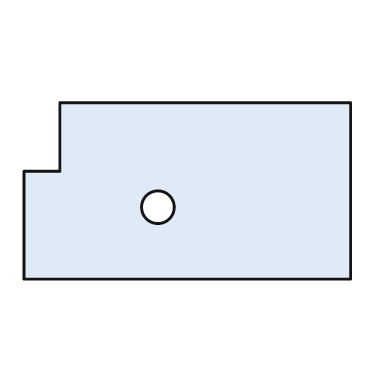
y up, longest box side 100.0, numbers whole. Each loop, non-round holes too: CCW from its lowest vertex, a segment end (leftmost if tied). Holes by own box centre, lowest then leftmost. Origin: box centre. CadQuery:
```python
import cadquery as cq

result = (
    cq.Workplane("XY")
    .moveTo(-50.0, -27.0)
    .lineTo(50.0, -27.0)
    .lineTo(50.0, 27.0)
    .lineTo(-39.0, 27.0)
    .lineTo(-39.0, 6.0)
    .lineTo(-50.0, 6.0)
    .close()
    .moveTo(-9.0, -5.0)
    .circle(5.0)
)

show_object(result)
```